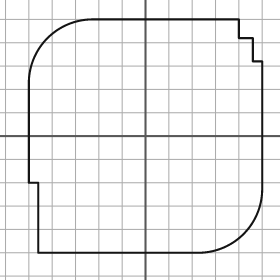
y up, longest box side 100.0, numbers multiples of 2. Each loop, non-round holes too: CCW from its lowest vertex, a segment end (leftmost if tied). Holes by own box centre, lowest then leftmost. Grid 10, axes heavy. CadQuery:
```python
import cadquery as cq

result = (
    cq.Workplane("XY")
    .moveTo(-46.0, -50.0)
    .lineTo(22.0, -50.0)
    .threePointArc((42.0, -42.0), (50.0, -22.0))
    .lineTo(50.0, 32.0)
    .lineTo(46.0, 32.0)
    .lineTo(46.0, 42.0)
    .lineTo(40.0, 42.0)
    .lineTo(40.0, 50.0)
    .lineTo(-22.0, 50.0)
    .threePointArc((-42.0, 42.0), (-50.0, 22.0))
    .lineTo(-50.0, -20.0)
    .lineTo(-46.0, -20.0)
    .close()
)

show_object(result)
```